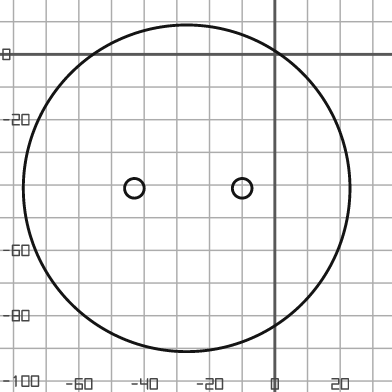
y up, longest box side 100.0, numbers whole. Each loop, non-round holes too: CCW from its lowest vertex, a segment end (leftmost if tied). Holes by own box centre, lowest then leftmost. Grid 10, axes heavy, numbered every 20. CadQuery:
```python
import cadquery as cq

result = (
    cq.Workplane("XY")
    .moveTo(-27.0, -41.0)
    .circle(50.0)
    .moveTo(-43.0, -41.0)
    .circle(3.0)
    .moveTo(-10.0, -41.0)
    .circle(3.0)
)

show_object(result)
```